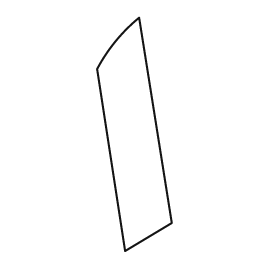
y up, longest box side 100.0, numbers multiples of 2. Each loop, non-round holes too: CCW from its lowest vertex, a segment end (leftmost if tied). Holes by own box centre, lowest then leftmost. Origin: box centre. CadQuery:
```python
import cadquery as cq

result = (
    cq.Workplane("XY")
    .moveTo(-4.0, -50.0)
    .lineTo(16.0, -38.0)
    .lineTo(2.0, 50.0)
    .threePointArc((-8.0, 40.0), (-16.0, 28.0))
    .close()
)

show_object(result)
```